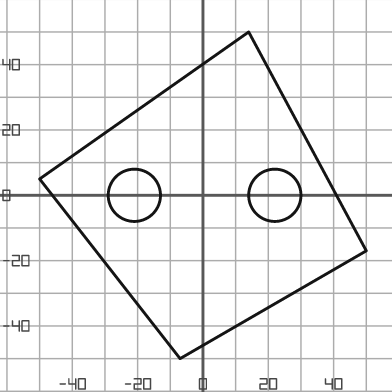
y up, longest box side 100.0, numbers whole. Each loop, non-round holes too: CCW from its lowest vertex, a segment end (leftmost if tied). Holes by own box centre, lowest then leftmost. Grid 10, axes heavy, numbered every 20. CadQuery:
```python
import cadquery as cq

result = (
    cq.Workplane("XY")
    .moveTo(-7.0, -50.0)
    .lineTo(50.0, -17.0)
    .lineTo(14.0, 50.0)
    .lineTo(-50.0, 5.0)
    .close()
    .moveTo(-21.0, 0.0)
    .circle(8.0)
    .moveTo(22.0, 0.0)
    .circle(8.0)
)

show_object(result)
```